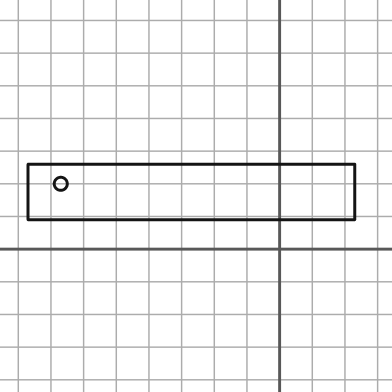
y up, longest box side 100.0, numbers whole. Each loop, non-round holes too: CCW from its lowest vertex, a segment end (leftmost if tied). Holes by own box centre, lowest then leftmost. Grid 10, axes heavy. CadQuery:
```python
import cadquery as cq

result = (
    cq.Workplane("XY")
    .moveTo(-77.0, 9.0)
    .lineTo(23.0, 9.0)
    .lineTo(23.0, 26.0)
    .lineTo(-77.0, 26.0)
    .close()
    .moveTo(-67.0, 20.0)
    .circle(2.0)
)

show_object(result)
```